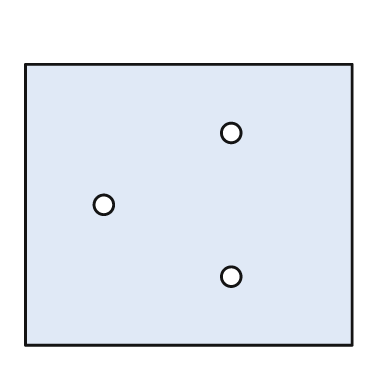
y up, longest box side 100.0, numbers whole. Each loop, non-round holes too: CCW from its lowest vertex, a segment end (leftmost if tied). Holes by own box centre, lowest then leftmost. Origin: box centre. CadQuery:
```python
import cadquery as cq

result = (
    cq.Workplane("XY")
    .moveTo(-50.0, -43.0)
    .lineTo(50.0, -43.0)
    .lineTo(50.0, 43.0)
    .lineTo(-50.0, 43.0)
    .close()
    .moveTo(13.0, -22.0)
    .circle(3.0)
    .moveTo(-26.0, 0.0)
    .circle(3.0)
    .moveTo(13.0, 22.0)
    .circle(3.0)
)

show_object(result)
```